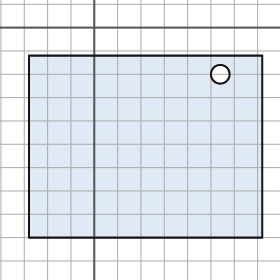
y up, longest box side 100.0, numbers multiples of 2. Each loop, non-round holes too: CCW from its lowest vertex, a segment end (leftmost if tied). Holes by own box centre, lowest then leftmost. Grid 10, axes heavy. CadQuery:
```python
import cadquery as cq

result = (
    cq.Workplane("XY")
    .moveTo(-28.0, -90.0)
    .lineTo(72.0, -90.0)
    .lineTo(72.0, -12.0)
    .lineTo(-28.0, -12.0)
    .close()
    .moveTo(54.0, -20.0)
    .circle(4.0)
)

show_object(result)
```